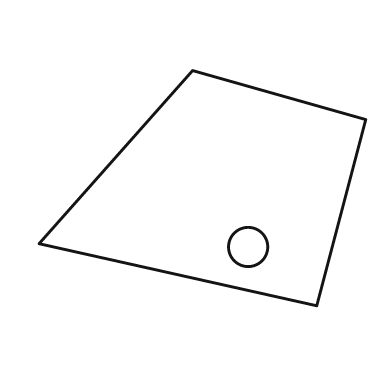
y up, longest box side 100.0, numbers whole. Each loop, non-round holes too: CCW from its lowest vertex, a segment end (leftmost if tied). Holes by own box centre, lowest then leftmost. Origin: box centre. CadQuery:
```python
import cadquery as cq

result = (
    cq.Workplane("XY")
    .moveTo(35.0, -36.0)
    .lineTo(50.0, 21.0)
    .lineTo(-3.0, 36.0)
    .lineTo(-50.0, -17.0)
    .close()
    .moveTo(14.0, -18.0)
    .circle(6.0)
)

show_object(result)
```